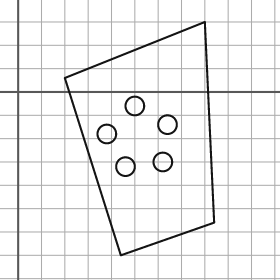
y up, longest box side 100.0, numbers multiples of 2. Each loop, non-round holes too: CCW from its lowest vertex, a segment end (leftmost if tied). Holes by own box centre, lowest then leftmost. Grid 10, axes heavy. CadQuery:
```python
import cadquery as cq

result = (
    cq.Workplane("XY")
    .moveTo(44.0, -70.0)
    .lineTo(84.0, -56.0)
    .lineTo(80.0, 30.0)
    .lineTo(20.0, 6.0)
    .close()
    .moveTo(46.0, -32.0)
    .circle(4.0)
    .moveTo(62.0, -30.0)
    .circle(4.0)
    .moveTo(38.0, -18.0)
    .circle(4.0)
    .moveTo(64.0, -14.0)
    .circle(4.0)
    .moveTo(50.0, -6.0)
    .circle(4.0)
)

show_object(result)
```